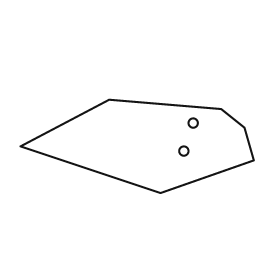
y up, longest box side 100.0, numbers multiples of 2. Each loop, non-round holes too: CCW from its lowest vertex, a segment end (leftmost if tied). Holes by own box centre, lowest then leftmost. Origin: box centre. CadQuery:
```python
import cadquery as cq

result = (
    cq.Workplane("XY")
    .moveTo(10.0, -20.0)
    .lineTo(50.0, -6.0)
    .lineTo(46.0, 8.0)
    .lineTo(36.0, 16.0)
    .lineTo(-12.0, 20.0)
    .lineTo(-50.0, 0.0)
    .close()
    .moveTo(20.0, -2.0)
    .circle(2.0)
    .moveTo(24.0, 10.0)
    .circle(2.0)
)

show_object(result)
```